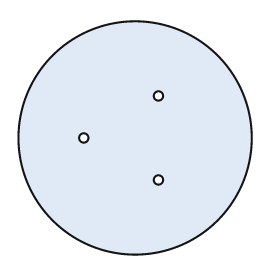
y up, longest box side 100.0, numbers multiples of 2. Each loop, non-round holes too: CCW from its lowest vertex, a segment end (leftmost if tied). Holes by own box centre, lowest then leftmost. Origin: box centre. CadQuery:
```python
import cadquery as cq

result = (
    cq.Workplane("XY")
    .moveTo(0.0, 0.0)
    .circle(50.0)
    .moveTo(10.0, -18.0)
    .circle(2.0)
    .moveTo(-22.0, 0.0)
    .circle(2.0)
    .moveTo(10.0, 18.0)
    .circle(2.0)
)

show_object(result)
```